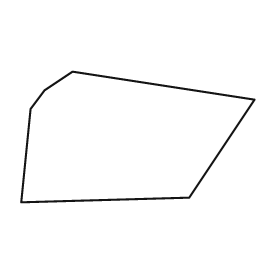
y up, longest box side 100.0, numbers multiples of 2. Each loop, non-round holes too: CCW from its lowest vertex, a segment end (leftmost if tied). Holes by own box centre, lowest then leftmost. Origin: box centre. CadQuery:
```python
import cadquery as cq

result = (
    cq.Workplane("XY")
    .moveTo(-50.0, -28.0)
    .lineTo(22.0, -26.0)
    .lineTo(50.0, 16.0)
    .lineTo(-28.0, 28.0)
    .lineTo(-40.0, 20.0)
    .lineTo(-46.0, 12.0)
    .close()
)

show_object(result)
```